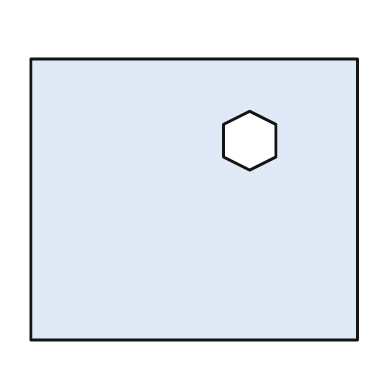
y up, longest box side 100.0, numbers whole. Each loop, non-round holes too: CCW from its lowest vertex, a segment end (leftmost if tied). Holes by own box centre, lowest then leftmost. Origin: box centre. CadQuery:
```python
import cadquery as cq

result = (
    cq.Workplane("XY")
    .moveTo(-50.0, -43.0)
    .lineTo(50.0, -43.0)
    .lineTo(50.0, 43.0)
    .lineTo(-50.0, 43.0)
    .close()
    .moveTo(17.0, 9.0)
    .lineTo(25.0, 13.0)
    .lineTo(25.0, 23.0)
    .lineTo(17.0, 27.0)
    .lineTo(9.0, 23.0)
    .lineTo(9.0, 13.0)
    .close()
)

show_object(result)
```